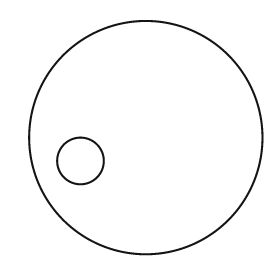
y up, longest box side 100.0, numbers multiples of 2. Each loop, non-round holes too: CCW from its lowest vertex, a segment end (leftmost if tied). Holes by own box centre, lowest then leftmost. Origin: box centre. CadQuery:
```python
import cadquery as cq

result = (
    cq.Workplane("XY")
    .moveTo(0.0, 0.0)
    .circle(50.0)
    .moveTo(-28.0, -10.0)
    .circle(10.0)
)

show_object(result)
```